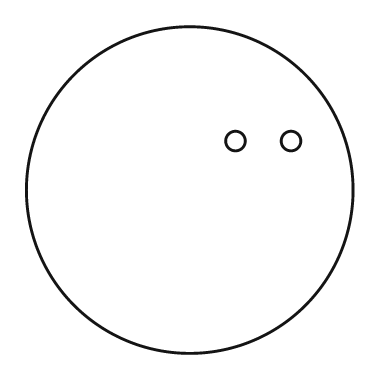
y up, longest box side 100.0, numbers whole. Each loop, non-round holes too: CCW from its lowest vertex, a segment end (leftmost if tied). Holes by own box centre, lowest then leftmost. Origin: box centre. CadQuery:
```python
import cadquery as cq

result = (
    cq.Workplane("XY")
    .moveTo(0.0, 0.0)
    .circle(50.0)
    .moveTo(14.0, 15.0)
    .circle(3.0)
    .moveTo(31.0, 15.0)
    .circle(3.0)
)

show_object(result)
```